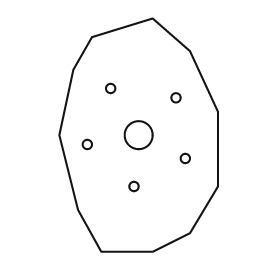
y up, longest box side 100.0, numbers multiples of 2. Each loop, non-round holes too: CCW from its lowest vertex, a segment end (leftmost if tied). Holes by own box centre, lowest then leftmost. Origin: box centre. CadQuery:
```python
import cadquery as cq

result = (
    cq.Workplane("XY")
    .moveTo(-16.0, -50.0)
    .lineTo(6.0, -50.0)
    .lineTo(22.0, -42.0)
    .lineTo(34.0, -22.0)
    .lineTo(34.0, 10.0)
    .lineTo(22.0, 36.0)
    .lineTo(6.0, 50.0)
    .lineTo(-20.0, 42.0)
    .lineTo(-28.0, 28.0)
    .lineTo(-34.0, 0.0)
    .lineTo(-26.0, -32.0)
    .close()
    .moveTo(-2.0, -22.0)
    .circle(2.0)
    .moveTo(20.0, -10.0)
    .circle(2.0)
    .moveTo(-22.0, -4.0)
    .circle(2.0)
    .moveTo(0.0, 0.0)
    .circle(6.0)
    .moveTo(16.0, 16.0)
    .circle(2.0)
    .moveTo(-12.0, 20.0)
    .circle(2.0)
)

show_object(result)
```